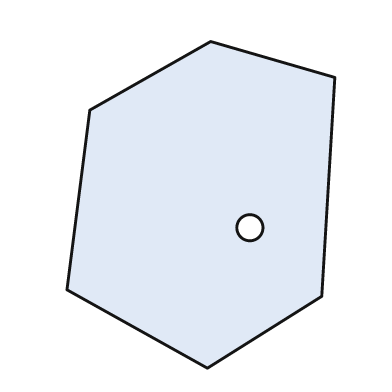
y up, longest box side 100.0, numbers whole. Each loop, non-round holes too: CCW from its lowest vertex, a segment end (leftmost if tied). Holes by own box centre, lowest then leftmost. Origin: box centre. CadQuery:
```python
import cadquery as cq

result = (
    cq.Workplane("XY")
    .moveTo(2.0, -50.0)
    .lineTo(37.0, -28.0)
    .lineTo(41.0, 39.0)
    .lineTo(3.0, 50.0)
    .lineTo(-34.0, 29.0)
    .lineTo(-41.0, -26.0)
    .close()
    .moveTo(15.0, -7.0)
    .circle(4.0)
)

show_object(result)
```